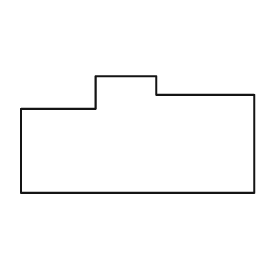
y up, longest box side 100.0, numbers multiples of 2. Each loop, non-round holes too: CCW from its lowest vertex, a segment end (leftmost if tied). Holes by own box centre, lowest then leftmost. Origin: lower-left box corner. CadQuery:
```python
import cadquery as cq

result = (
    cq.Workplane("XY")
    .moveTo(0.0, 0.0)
    .lineTo(100.0, 0.0)
    .lineTo(100.0, 42.0)
    .lineTo(58.0, 42.0)
    .lineTo(58.0, 50.0)
    .lineTo(32.0, 50.0)
    .lineTo(32.0, 36.0)
    .lineTo(0.0, 36.0)
    .close()
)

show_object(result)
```